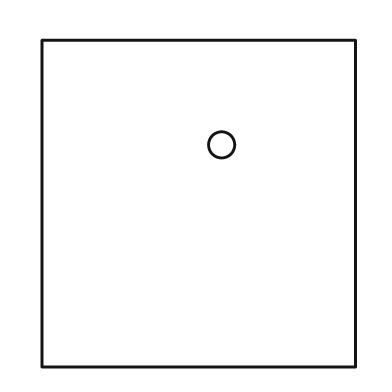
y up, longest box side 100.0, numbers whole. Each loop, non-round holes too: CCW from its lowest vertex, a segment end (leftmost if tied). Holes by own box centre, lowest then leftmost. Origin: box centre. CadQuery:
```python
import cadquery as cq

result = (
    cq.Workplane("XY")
    .moveTo(-48.0, -50.0)
    .lineTo(48.0, -50.0)
    .lineTo(48.0, 50.0)
    .lineTo(-48.0, 50.0)
    .close()
    .moveTo(7.0, 18.0)
    .circle(4.0)
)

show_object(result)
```